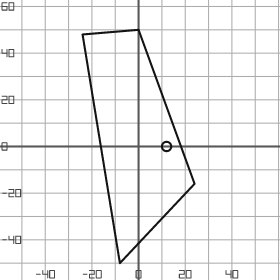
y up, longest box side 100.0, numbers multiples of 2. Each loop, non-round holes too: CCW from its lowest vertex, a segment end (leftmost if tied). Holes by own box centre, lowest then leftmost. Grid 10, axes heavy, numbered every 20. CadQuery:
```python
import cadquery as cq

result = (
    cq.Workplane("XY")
    .moveTo(-8.0, -50.0)
    .lineTo(24.0, -16.0)
    .lineTo(0.0, 50.0)
    .lineTo(-24.0, 48.0)
    .close()
    .moveTo(12.0, 0.0)
    .circle(2.0)
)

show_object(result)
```